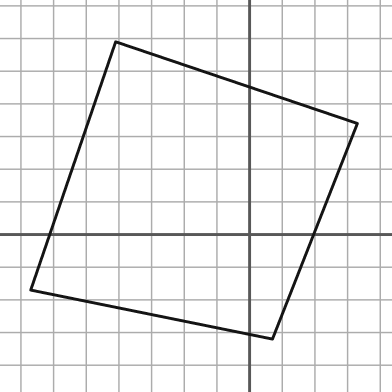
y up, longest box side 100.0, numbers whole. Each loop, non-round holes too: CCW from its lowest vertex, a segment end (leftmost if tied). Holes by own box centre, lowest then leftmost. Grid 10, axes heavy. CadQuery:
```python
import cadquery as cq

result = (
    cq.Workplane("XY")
    .moveTo(7.0, -32.0)
    .lineTo(33.0, 34.0)
    .lineTo(-41.0, 59.0)
    .lineTo(-67.0, -17.0)
    .close()
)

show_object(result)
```